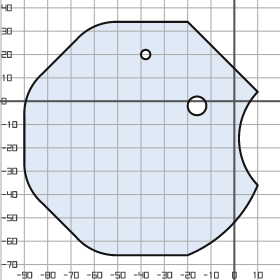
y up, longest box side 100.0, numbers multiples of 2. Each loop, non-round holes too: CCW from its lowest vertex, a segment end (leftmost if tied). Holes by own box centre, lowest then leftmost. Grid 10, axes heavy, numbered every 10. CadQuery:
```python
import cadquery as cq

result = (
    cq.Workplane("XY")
    .moveTo(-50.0, -66.0)
    .lineTo(-20.0, -66.0)
    .threePointArc((-2.0, -54.0), (10.0, -36.0))
    .threePointArc((2.0, -16.0), (10.0, 4.0))
    .lineTo(-20.0, 34.0)
    .lineTo(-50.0, 34.0)
    .threePointArc((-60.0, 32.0), (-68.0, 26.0))
    .lineTo(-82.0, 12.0)
    .threePointArc((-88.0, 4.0), (-90.0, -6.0))
    .lineTo(-90.0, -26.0)
    .threePointArc((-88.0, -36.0), (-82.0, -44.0))
    .lineTo(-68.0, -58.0)
    .threePointArc((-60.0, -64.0), (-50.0, -66.0))
    .close()
    .moveTo(-16.0, -2.0)
    .circle(4.0)
    .moveTo(-38.0, 20.0)
    .circle(2.0)
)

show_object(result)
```